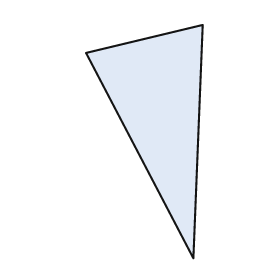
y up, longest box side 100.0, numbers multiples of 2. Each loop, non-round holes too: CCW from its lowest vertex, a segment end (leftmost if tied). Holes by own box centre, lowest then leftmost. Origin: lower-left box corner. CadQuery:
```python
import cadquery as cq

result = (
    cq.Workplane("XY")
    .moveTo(46.0, 0.0)
    .lineTo(50.0, 100.0)
    .lineTo(0.0, 88.0)
    .close()
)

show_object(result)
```